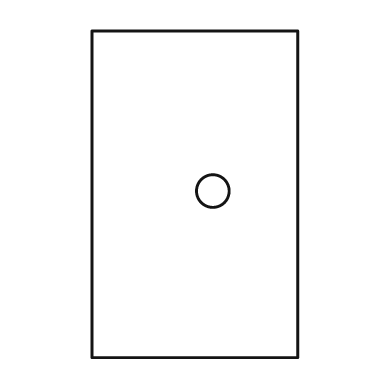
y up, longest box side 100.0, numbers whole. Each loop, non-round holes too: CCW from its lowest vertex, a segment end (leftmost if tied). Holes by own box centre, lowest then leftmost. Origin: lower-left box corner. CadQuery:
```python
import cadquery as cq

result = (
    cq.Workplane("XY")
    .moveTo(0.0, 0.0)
    .lineTo(63.0, 0.0)
    .lineTo(63.0, 100.0)
    .lineTo(0.0, 100.0)
    .close()
    .moveTo(37.0, 51.0)
    .circle(5.0)
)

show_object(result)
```